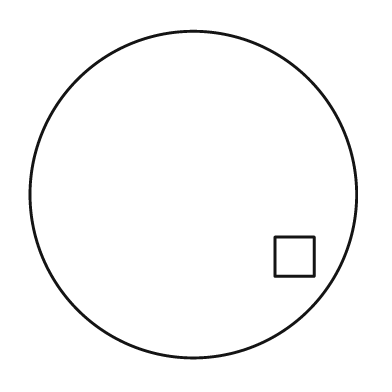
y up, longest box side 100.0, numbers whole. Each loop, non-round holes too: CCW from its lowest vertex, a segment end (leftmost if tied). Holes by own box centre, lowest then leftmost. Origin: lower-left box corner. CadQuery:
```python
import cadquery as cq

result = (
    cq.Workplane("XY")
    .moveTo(50.0, 50.0)
    .circle(50.0)
    .moveTo(75.0, 25.0)
    .lineTo(87.0, 25.0)
    .lineTo(87.0, 37.0)
    .lineTo(75.0, 37.0)
    .close()
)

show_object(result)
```